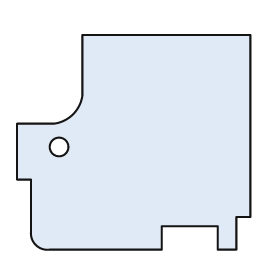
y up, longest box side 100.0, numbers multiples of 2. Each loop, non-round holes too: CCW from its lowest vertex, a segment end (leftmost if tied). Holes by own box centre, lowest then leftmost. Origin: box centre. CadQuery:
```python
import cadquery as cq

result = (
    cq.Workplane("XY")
    .moveTo(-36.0, -46.0)
    .lineTo(12.0, -46.0)
    .lineTo(12.0, -36.0)
    .lineTo(36.0, -36.0)
    .lineTo(36.0, -46.0)
    .lineTo(44.0, -46.0)
    .lineTo(44.0, -32.0)
    .lineTo(50.0, -32.0)
    .lineTo(50.0, 46.0)
    .lineTo(-22.0, 46.0)
    .lineTo(-22.0, 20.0)
    .threePointArc((-26.0, 12.0), (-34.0, 8.0))
    .lineTo(-50.0, 8.0)
    .lineTo(-50.0, -16.0)
    .lineTo(-44.0, -16.0)
    .lineTo(-44.0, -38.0)
    .threePointArc((-42.0, -44.0), (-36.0, -46.0))
    .close()
    .moveTo(-32.0, -2.0)
    .circle(4.0)
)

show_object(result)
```